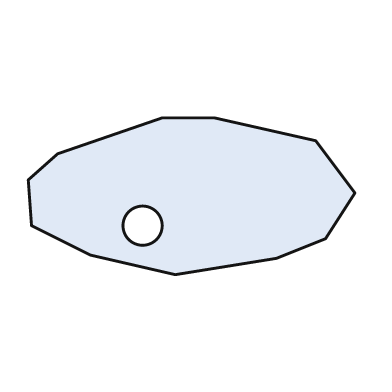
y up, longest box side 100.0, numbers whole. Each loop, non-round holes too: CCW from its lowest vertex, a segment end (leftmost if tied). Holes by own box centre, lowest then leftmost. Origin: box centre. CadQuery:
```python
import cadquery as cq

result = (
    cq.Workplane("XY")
    .moveTo(-5.0, -24.0)
    .lineTo(26.0, -19.0)
    .lineTo(41.0, -13.0)
    .lineTo(50.0, 1.0)
    .lineTo(38.0, 17.0)
    .lineTo(7.0, 24.0)
    .lineTo(-9.0, 24.0)
    .lineTo(-41.0, 13.0)
    .lineTo(-50.0, 5.0)
    .lineTo(-49.0, -9.0)
    .lineTo(-31.0, -18.0)
    .close()
    .moveTo(-15.0, -9.0)
    .circle(6.0)
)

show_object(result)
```